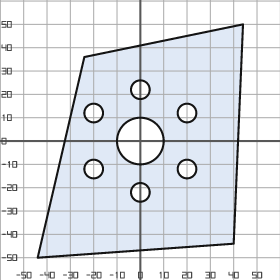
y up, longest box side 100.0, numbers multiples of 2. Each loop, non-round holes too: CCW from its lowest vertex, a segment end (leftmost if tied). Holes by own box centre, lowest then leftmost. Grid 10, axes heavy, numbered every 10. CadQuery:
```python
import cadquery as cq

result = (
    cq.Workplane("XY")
    .moveTo(-44.0, -50.0)
    .lineTo(40.0, -44.0)
    .lineTo(44.0, 50.0)
    .lineTo(-24.0, 36.0)
    .close()
    .moveTo(0.0, -22.0)
    .circle(4.0)
    .moveTo(-20.0, -12.0)
    .circle(4.0)
    .moveTo(20.0, -12.0)
    .circle(4.0)
    .moveTo(0.0, 0.0)
    .circle(10.0)
    .moveTo(-20.0, 12.0)
    .circle(4.0)
    .moveTo(20.0, 12.0)
    .circle(4.0)
    .moveTo(0.0, 22.0)
    .circle(4.0)
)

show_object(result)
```